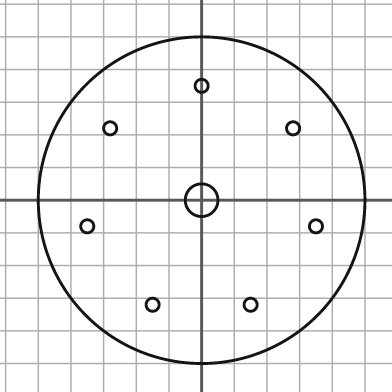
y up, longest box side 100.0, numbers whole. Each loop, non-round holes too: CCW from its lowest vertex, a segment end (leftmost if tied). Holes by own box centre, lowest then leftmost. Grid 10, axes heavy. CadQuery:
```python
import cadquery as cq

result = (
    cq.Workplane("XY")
    .moveTo(0.0, 0.0)
    .circle(50.0)
    .moveTo(-15.0, -32.0)
    .circle(2.0)
    .moveTo(15.0, -32.0)
    .circle(2.0)
    .moveTo(-35.0, -8.0)
    .circle(2.0)
    .moveTo(35.0, -8.0)
    .circle(2.0)
    .moveTo(0.0, 0.0)
    .circle(5.0)
    .moveTo(-28.0, 22.0)
    .circle(2.0)
    .moveTo(28.0, 22.0)
    .circle(2.0)
    .moveTo(0.0, 35.0)
    .circle(2.0)
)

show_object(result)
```